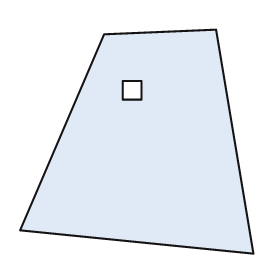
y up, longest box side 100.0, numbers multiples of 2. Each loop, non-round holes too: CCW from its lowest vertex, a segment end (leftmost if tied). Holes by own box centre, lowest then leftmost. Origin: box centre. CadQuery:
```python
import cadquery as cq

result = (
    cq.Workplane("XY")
    .moveTo(50.0, -48.0)
    .lineTo(34.0, 48.0)
    .lineTo(-14.0, 46.0)
    .lineTo(-50.0, -38.0)
    .close()
    .moveTo(-6.0, 18.0)
    .lineTo(2.0, 18.0)
    .lineTo(2.0, 26.0)
    .lineTo(-6.0, 26.0)
    .close()
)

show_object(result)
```